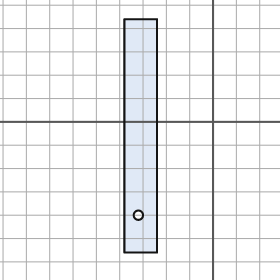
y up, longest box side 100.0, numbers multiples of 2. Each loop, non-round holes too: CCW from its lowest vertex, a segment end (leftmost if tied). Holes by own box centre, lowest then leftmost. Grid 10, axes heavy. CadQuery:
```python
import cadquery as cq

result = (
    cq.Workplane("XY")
    .moveTo(-38.0, -56.0)
    .lineTo(-24.0, -56.0)
    .lineTo(-24.0, 44.0)
    .lineTo(-38.0, 44.0)
    .close()
    .moveTo(-32.0, -40.0)
    .circle(2.0)
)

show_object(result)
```